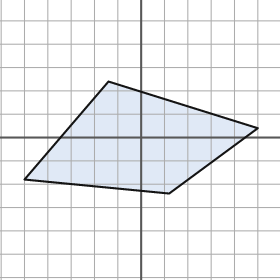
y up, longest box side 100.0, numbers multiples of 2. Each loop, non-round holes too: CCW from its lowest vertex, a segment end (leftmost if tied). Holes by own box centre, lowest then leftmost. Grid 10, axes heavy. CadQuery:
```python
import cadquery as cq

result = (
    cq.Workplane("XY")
    .moveTo(12.0, -24.0)
    .lineTo(50.0, 4.0)
    .lineTo(-14.0, 24.0)
    .lineTo(-50.0, -18.0)
    .close()
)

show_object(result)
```